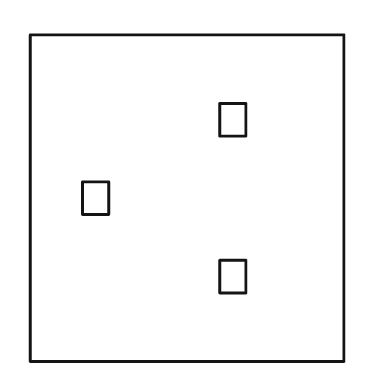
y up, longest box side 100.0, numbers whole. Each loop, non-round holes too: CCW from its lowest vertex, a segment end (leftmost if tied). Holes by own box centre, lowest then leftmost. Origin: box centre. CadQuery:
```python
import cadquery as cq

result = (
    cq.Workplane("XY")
    .moveTo(-48.0, -50.0)
    .lineTo(48.0, -50.0)
    .lineTo(48.0, 50.0)
    .lineTo(-48.0, 50.0)
    .close()
    .moveTo(10.0, -29.0)
    .lineTo(18.0, -29.0)
    .lineTo(18.0, -19.0)
    .lineTo(10.0, -19.0)
    .close()
    .moveTo(-32.0, -5.0)
    .lineTo(-24.0, -5.0)
    .lineTo(-24.0, 5.0)
    .lineTo(-32.0, 5.0)
    .close()
    .moveTo(10.0, 19.0)
    .lineTo(18.0, 19.0)
    .lineTo(18.0, 29.0)
    .lineTo(10.0, 29.0)
    .close()
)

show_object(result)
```